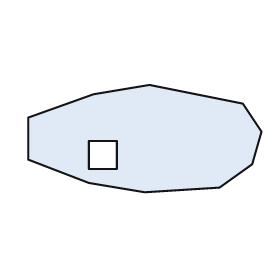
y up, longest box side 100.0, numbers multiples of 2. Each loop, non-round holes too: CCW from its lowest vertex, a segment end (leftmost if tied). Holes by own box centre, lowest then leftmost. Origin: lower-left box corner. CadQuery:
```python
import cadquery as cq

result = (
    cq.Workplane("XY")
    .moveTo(50.0, 0.0)
    .lineTo(82.0, 2.0)
    .lineTo(96.0, 12.0)
    .lineTo(100.0, 26.0)
    .lineTo(92.0, 38.0)
    .lineTo(52.0, 46.0)
    .lineTo(28.0, 42.0)
    .lineTo(0.0, 32.0)
    .lineTo(0.0, 14.0)
    .lineTo(26.0, 4.0)
    .close()
    .moveTo(26.0, 10.0)
    .lineTo(38.0, 10.0)
    .lineTo(38.0, 22.0)
    .lineTo(26.0, 22.0)
    .close()
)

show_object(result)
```